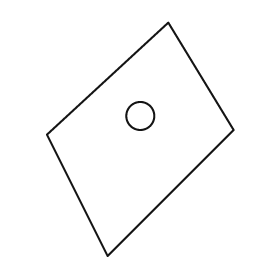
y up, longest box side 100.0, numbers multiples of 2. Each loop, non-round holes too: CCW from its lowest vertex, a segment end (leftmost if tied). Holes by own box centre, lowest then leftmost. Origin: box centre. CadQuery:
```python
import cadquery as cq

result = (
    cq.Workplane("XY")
    .moveTo(-14.0, -50.0)
    .lineTo(40.0, 4.0)
    .lineTo(12.0, 50.0)
    .lineTo(-40.0, 2.0)
    .close()
    .moveTo(0.0, 10.0)
    .circle(6.0)
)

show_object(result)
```